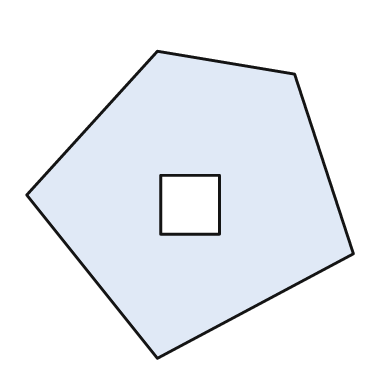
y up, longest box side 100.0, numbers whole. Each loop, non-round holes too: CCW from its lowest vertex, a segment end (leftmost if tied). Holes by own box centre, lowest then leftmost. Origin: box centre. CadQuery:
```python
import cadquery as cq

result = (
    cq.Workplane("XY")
    .moveTo(-10.0, -47.0)
    .lineTo(50.0, -15.0)
    .lineTo(32.0, 40.0)
    .lineTo(-10.0, 47.0)
    .lineTo(-50.0, 3.0)
    .close()
    .moveTo(-9.0, -9.0)
    .lineTo(9.0, -9.0)
    .lineTo(9.0, 9.0)
    .lineTo(-9.0, 9.0)
    .close()
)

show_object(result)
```